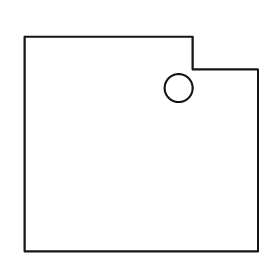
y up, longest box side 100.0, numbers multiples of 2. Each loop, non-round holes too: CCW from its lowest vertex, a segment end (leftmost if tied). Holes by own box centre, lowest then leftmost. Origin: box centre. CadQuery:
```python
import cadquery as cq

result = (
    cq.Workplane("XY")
    .moveTo(-50.0, -46.0)
    .lineTo(50.0, -46.0)
    .lineTo(50.0, 32.0)
    .lineTo(22.0, 32.0)
    .lineTo(22.0, 46.0)
    .lineTo(-50.0, 46.0)
    .close()
    .moveTo(16.0, 24.0)
    .circle(6.0)
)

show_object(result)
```